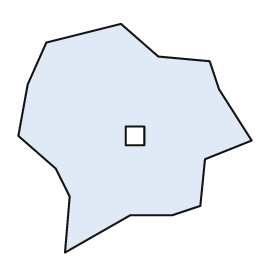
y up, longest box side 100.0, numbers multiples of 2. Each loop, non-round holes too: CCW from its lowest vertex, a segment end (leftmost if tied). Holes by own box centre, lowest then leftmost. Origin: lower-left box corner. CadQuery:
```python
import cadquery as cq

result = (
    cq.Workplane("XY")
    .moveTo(20.0, 0.0)
    .lineTo(48.0, 16.0)
    .lineTo(66.0, 16.0)
    .lineTo(78.0, 20.0)
    .lineTo(80.0, 40.0)
    .lineTo(100.0, 48.0)
    .lineTo(86.0, 70.0)
    .lineTo(82.0, 82.0)
    .lineTo(60.0, 84.0)
    .lineTo(44.0, 98.0)
    .lineTo(12.0, 90.0)
    .lineTo(4.0, 72.0)
    .lineTo(0.0, 50.0)
    .lineTo(16.0, 36.0)
    .lineTo(22.0, 24.0)
    .close()
    .moveTo(46.0, 46.0)
    .lineTo(54.0, 46.0)
    .lineTo(54.0, 54.0)
    .lineTo(46.0, 54.0)
    .close()
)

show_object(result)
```